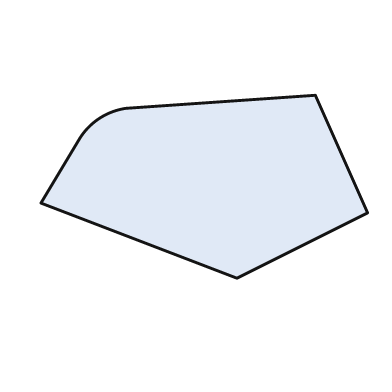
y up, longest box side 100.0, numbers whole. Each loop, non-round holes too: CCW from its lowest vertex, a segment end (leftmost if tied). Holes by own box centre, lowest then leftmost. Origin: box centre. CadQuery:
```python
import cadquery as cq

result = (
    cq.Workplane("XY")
    .moveTo(10.0, -28.0)
    .lineTo(50.0, -8.0)
    .lineTo(34.0, 28.0)
    .lineTo(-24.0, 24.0)
    .threePointArc((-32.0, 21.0), (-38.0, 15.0))
    .lineTo(-50.0, -5.0)
    .close()
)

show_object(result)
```